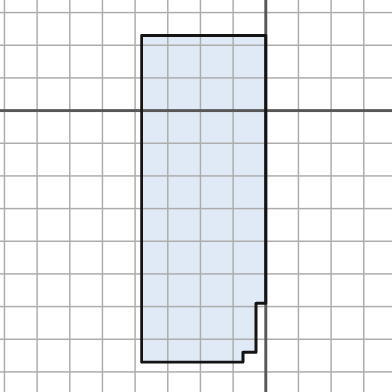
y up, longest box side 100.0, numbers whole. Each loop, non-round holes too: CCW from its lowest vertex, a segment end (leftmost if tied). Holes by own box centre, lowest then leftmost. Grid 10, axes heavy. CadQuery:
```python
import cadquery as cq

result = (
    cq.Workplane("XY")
    .moveTo(-38.0, -77.0)
    .lineTo(-7.0, -77.0)
    .lineTo(-7.0, -74.0)
    .lineTo(-3.0, -74.0)
    .lineTo(-3.0, -59.0)
    .lineTo(0.0, -59.0)
    .lineTo(0.0, 23.0)
    .lineTo(-38.0, 23.0)
    .close()
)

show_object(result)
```